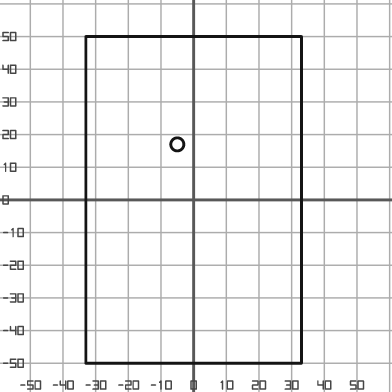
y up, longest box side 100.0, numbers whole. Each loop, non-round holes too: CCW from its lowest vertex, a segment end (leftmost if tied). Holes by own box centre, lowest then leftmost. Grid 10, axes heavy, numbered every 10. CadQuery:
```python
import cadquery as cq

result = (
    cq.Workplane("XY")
    .moveTo(-33.0, -50.0)
    .lineTo(33.0, -50.0)
    .lineTo(33.0, 50.0)
    .lineTo(-33.0, 50.0)
    .close()
    .moveTo(-5.0, 17.0)
    .circle(2.0)
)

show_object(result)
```